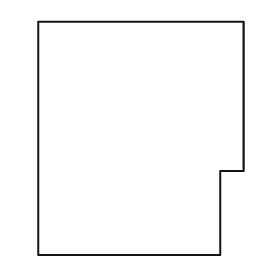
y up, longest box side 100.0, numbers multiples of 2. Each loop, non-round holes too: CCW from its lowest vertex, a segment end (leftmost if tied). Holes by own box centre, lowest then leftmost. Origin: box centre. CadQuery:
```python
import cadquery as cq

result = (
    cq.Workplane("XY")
    .moveTo(-44.0, -50.0)
    .lineTo(34.0, -50.0)
    .lineTo(34.0, -14.0)
    .lineTo(44.0, -14.0)
    .lineTo(44.0, 50.0)
    .lineTo(-44.0, 50.0)
    .close()
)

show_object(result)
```